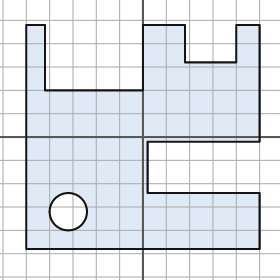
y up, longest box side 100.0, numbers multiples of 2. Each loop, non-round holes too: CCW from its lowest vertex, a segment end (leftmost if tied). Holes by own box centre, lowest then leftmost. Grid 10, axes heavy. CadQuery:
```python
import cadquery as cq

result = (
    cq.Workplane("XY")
    .moveTo(-50.0, -48.0)
    .lineTo(50.0, -48.0)
    .lineTo(50.0, -24.0)
    .lineTo(2.0, -24.0)
    .lineTo(2.0, -2.0)
    .lineTo(50.0, -2.0)
    .lineTo(50.0, 48.0)
    .lineTo(40.0, 48.0)
    .lineTo(40.0, 32.0)
    .lineTo(18.0, 32.0)
    .lineTo(18.0, 48.0)
    .lineTo(0.0, 48.0)
    .lineTo(0.0, 20.0)
    .lineTo(-42.0, 20.0)
    .lineTo(-42.0, 48.0)
    .lineTo(-50.0, 48.0)
    .close()
    .moveTo(-32.0, -32.0)
    .circle(8.0)
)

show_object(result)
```